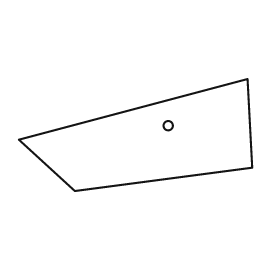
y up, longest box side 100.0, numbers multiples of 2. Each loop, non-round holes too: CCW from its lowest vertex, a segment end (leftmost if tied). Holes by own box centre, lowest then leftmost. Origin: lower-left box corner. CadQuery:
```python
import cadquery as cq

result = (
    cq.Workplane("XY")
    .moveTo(24.0, 0.0)
    .lineTo(100.0, 10.0)
    .lineTo(98.0, 48.0)
    .lineTo(0.0, 22.0)
    .close()
    .moveTo(64.0, 28.0)
    .circle(2.0)
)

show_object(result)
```